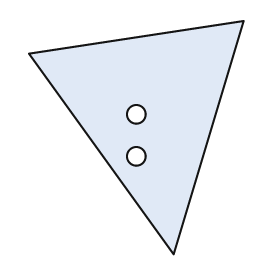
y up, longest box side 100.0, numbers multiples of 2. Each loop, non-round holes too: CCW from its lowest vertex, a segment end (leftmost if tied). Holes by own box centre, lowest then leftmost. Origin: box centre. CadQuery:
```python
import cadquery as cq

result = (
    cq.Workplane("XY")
    .moveTo(16.0, -50.0)
    .lineTo(46.0, 50.0)
    .lineTo(-46.0, 36.0)
    .close()
    .moveTo(0.0, -8.0)
    .circle(4.0)
    .moveTo(0.0, 10.0)
    .circle(4.0)
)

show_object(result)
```